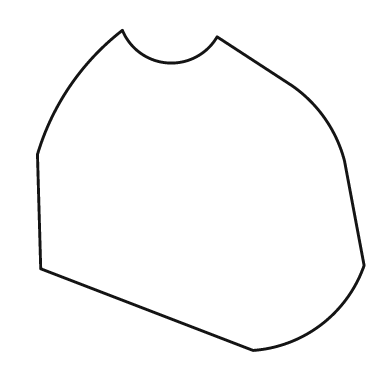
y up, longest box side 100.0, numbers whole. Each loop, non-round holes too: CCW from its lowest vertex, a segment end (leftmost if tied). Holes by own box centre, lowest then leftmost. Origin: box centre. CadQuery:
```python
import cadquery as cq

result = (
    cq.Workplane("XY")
    .moveTo(16.0, -49.0)
    .threePointArc((37.0, -41.0), (50.0, -23.0))
    .lineTo(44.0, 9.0)
    .threePointArc((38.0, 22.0), (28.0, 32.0))
    .lineTo(5.0, 47.0)
    .threePointArc((-10.0, 39.0), (-24.0, 49.0))
    .threePointArc((-40.0, 32.0), (-50.0, 11.0))
    .lineTo(-49.0, -24.0)
    .close()
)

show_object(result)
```